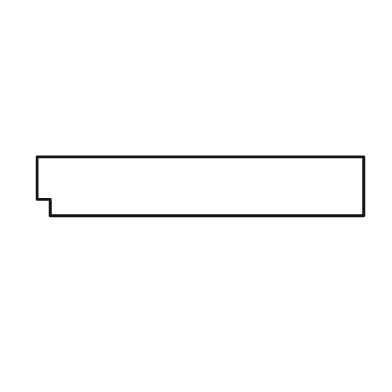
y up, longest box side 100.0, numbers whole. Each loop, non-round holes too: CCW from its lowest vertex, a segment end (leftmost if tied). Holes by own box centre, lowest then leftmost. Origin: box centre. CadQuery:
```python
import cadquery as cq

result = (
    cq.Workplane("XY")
    .moveTo(-46.0, -9.0)
    .lineTo(50.0, -9.0)
    .lineTo(50.0, 9.0)
    .lineTo(-50.0, 9.0)
    .lineTo(-50.0, -4.0)
    .lineTo(-46.0, -4.0)
    .close()
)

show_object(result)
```